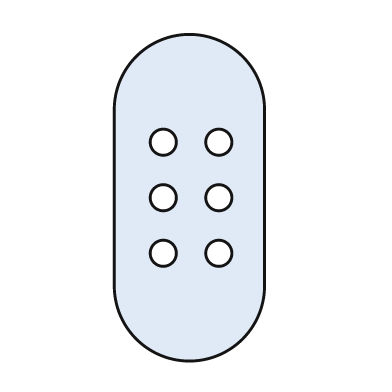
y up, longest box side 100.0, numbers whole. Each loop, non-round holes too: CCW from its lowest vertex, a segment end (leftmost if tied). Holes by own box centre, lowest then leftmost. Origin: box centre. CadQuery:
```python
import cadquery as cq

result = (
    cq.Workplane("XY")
    .moveTo(-23.0, -27.0)
    .threePointArc((0.0, -50.0), (23.0, -27.0))
    .lineTo(23.0, 27.0)
    .threePointArc((0.0, 50.0), (-23.0, 27.0))
    .close()
    .moveTo(-8.0, -17.0)
    .circle(4.0)
    .moveTo(9.0, -17.0)
    .circle(4.0)
    .moveTo(-8.0, 0.0)
    .circle(4.0)
    .moveTo(9.0, 0.0)
    .circle(4.0)
    .moveTo(-8.0, 17.0)
    .circle(4.0)
    .moveTo(9.0, 17.0)
    .circle(4.0)
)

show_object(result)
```